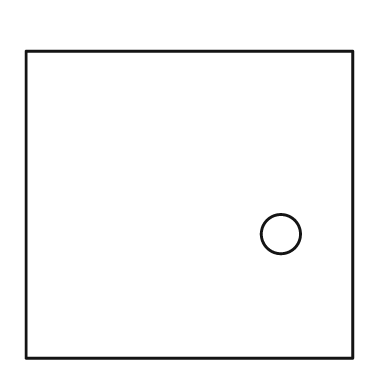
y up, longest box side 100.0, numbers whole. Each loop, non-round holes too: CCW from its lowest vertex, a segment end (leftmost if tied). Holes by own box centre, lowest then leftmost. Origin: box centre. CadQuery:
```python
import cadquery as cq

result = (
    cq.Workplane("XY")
    .moveTo(-50.0, -47.0)
    .lineTo(50.0, -47.0)
    .lineTo(50.0, 47.0)
    .lineTo(-50.0, 47.0)
    .close()
    .moveTo(28.0, -9.0)
    .circle(6.0)
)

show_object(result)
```